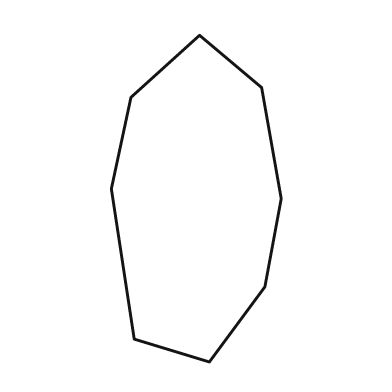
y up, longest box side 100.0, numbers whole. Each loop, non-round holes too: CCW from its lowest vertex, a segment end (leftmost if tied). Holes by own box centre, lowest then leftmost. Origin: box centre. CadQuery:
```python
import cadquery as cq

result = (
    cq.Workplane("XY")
    .moveTo(4.0, -50.0)
    .lineTo(21.0, -27.0)
    .lineTo(26.0, 0.0)
    .lineTo(20.0, 34.0)
    .lineTo(1.0, 50.0)
    .lineTo(-20.0, 31.0)
    .lineTo(-26.0, 3.0)
    .lineTo(-19.0, -43.0)
    .close()
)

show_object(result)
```